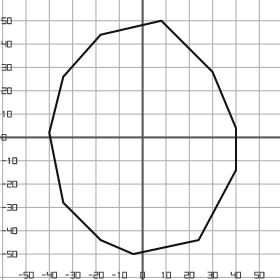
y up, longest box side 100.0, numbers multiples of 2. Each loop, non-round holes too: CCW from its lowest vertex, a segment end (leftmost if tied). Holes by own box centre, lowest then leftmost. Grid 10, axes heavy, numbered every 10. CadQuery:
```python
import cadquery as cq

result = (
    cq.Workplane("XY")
    .moveTo(-4.0, -50.0)
    .lineTo(24.0, -44.0)
    .lineTo(40.0, -14.0)
    .lineTo(40.0, 4.0)
    .lineTo(30.0, 28.0)
    .lineTo(8.0, 50.0)
    .lineTo(-18.0, 44.0)
    .lineTo(-34.0, 26.0)
    .lineTo(-40.0, 2.0)
    .lineTo(-34.0, -28.0)
    .lineTo(-18.0, -44.0)
    .close()
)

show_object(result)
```